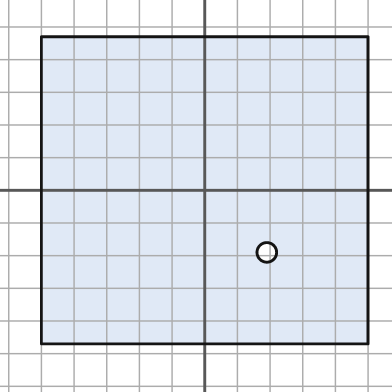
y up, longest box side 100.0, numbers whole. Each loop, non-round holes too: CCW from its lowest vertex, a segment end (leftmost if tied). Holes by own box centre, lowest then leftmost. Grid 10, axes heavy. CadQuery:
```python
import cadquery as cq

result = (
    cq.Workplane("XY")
    .moveTo(-50.0, -47.0)
    .lineTo(50.0, -47.0)
    .lineTo(50.0, 47.0)
    .lineTo(-50.0, 47.0)
    .close()
    .moveTo(19.0, -19.0)
    .circle(3.0)
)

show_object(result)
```